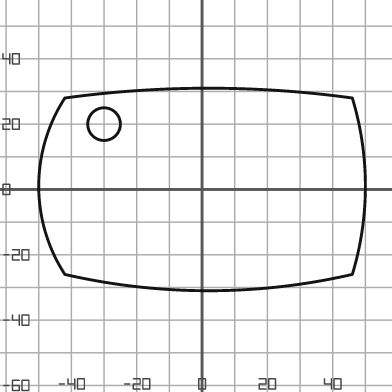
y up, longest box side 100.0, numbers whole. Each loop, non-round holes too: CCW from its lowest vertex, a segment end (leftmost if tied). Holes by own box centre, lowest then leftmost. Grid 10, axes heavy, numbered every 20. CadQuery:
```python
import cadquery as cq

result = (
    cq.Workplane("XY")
    .moveTo(-42.0, -26.0)
    .threePointArc((2.0, -31.0), (46.0, -26.0))
    .threePointArc((50.0, 1.0), (46.0, 28.0))
    .threePointArc((2.0, 31.0), (-42.0, 28.0))
    .threePointArc((-50.0, 1.0), (-42.0, -26.0))
    .close()
    .moveTo(-30.0, 20.0)
    .circle(5.0)
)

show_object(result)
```